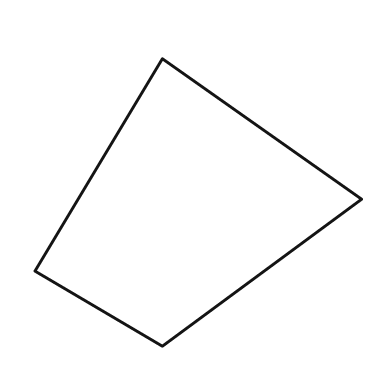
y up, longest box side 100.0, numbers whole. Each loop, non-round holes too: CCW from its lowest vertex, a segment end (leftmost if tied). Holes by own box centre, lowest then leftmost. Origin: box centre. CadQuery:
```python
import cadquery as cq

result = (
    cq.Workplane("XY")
    .moveTo(-11.0, -44.0)
    .lineTo(50.0, 1.0)
    .lineTo(-11.0, 44.0)
    .lineTo(-50.0, -21.0)
    .close()
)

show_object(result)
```